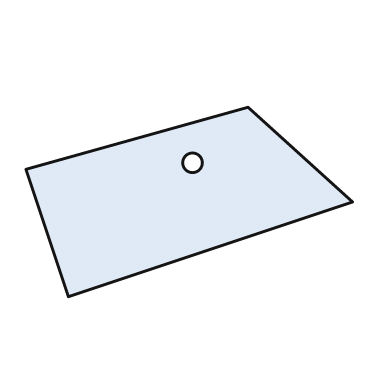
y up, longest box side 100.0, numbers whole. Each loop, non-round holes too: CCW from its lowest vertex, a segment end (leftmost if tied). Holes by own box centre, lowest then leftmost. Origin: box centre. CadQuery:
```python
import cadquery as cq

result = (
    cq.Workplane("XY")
    .moveTo(-37.0, -29.0)
    .lineTo(50.0, 0.0)
    .lineTo(18.0, 29.0)
    .lineTo(-50.0, 10.0)
    .close()
    .moveTo(1.0, 12.0)
    .circle(3.0)
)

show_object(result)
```